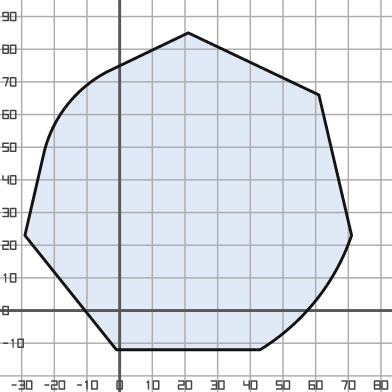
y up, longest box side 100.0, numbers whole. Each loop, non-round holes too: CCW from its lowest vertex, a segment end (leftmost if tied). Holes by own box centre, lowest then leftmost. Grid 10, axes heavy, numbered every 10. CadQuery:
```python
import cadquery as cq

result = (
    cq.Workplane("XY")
    .moveTo(-1.0, -12.0)
    .lineTo(43.0, -12.0)
    .threePointArc((60.0, 3.0), (71.0, 23.0))
    .lineTo(61.0, 66.0)
    .lineTo(21.0, 85.0)
    .lineTo(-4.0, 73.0)
    .threePointArc((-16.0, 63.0), (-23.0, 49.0))
    .lineTo(-29.0, 23.0)
    .close()
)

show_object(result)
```